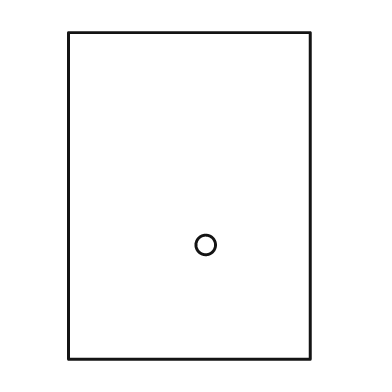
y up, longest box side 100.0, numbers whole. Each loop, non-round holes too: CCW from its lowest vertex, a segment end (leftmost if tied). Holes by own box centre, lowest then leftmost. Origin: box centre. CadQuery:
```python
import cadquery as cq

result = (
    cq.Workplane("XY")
    .moveTo(-37.0, -50.0)
    .lineTo(37.0, -50.0)
    .lineTo(37.0, 50.0)
    .lineTo(-37.0, 50.0)
    .close()
    .moveTo(5.0, -15.0)
    .circle(3.0)
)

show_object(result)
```